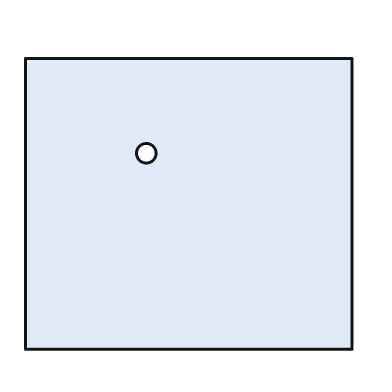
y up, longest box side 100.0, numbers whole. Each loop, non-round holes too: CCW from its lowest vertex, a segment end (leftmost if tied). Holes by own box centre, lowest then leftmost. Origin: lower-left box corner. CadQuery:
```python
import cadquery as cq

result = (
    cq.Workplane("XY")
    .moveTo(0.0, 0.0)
    .lineTo(100.0, 0.0)
    .lineTo(100.0, 89.0)
    .lineTo(0.0, 89.0)
    .close()
    .moveTo(37.0, 60.0)
    .circle(3.0)
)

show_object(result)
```